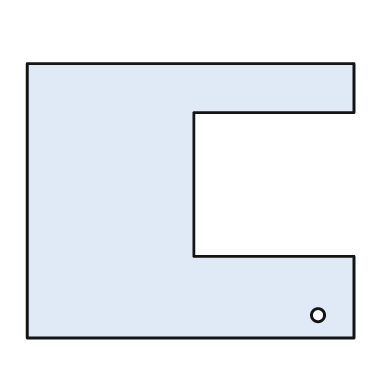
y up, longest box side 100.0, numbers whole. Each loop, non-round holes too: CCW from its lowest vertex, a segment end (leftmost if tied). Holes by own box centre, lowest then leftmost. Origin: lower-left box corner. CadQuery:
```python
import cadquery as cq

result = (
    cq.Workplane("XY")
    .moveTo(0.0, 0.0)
    .lineTo(100.0, 0.0)
    .lineTo(100.0, 25.0)
    .lineTo(51.0, 25.0)
    .lineTo(51.0, 69.0)
    .lineTo(100.0, 69.0)
    .lineTo(100.0, 84.0)
    .lineTo(0.0, 84.0)
    .close()
    .moveTo(89.0, 7.0)
    .circle(2.0)
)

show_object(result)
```